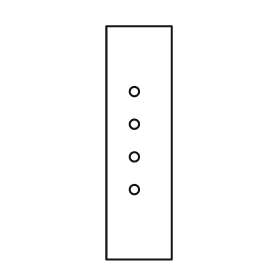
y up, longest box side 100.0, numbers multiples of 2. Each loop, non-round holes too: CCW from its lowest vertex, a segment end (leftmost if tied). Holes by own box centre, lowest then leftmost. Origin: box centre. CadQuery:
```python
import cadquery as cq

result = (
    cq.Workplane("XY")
    .moveTo(-14.0, -50.0)
    .lineTo(14.0, -50.0)
    .lineTo(14.0, 50.0)
    .lineTo(-14.0, 50.0)
    .close()
    .moveTo(-2.0, -20.0)
    .circle(2.0)
    .moveTo(-2.0, -6.0)
    .circle(2.0)
    .moveTo(-2.0, 8.0)
    .circle(2.0)
    .moveTo(-2.0, 22.0)
    .circle(2.0)
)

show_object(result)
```